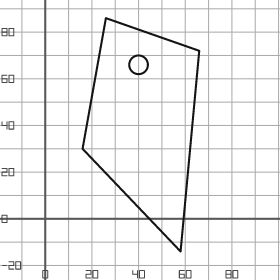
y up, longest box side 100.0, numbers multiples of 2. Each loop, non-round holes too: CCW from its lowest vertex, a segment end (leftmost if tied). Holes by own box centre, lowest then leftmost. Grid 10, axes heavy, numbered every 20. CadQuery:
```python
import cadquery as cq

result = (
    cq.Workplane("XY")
    .moveTo(58.0, -14.0)
    .lineTo(66.0, 72.0)
    .lineTo(26.0, 86.0)
    .lineTo(16.0, 30.0)
    .close()
    .moveTo(40.0, 66.0)
    .circle(4.0)
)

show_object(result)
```